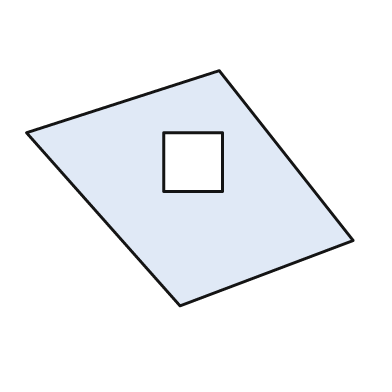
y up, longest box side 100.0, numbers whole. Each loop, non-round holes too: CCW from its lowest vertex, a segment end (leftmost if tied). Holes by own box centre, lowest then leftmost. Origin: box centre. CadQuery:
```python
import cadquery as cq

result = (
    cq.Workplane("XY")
    .moveTo(-3.0, -36.0)
    .lineTo(50.0, -16.0)
    .lineTo(9.0, 36.0)
    .lineTo(-50.0, 17.0)
    .close()
    .moveTo(-8.0, -1.0)
    .lineTo(10.0, -1.0)
    .lineTo(10.0, 17.0)
    .lineTo(-8.0, 17.0)
    .close()
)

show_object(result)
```